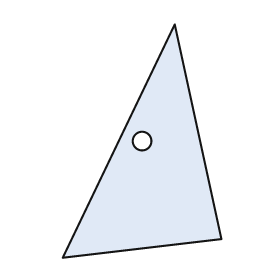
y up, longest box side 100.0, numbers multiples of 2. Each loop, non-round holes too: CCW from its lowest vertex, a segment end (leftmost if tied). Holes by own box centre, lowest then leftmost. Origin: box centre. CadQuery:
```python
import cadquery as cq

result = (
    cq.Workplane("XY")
    .moveTo(-34.0, -50.0)
    .lineTo(34.0, -42.0)
    .lineTo(14.0, 50.0)
    .close()
    .moveTo(0.0, 0.0)
    .circle(4.0)
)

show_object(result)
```